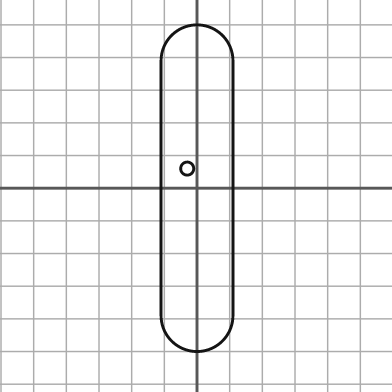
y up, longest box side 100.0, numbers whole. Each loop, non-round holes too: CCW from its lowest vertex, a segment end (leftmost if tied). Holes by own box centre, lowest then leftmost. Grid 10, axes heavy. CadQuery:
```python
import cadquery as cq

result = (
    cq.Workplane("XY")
    .moveTo(-11.0, -39.0)
    .threePointArc((0.0, -50.0), (11.0, -39.0))
    .lineTo(11.0, 39.0)
    .threePointArc((0.0, 50.0), (-11.0, 39.0))
    .close()
    .moveTo(-3.0, 6.0)
    .circle(2.0)
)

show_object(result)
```